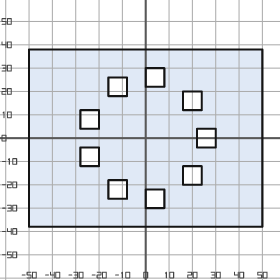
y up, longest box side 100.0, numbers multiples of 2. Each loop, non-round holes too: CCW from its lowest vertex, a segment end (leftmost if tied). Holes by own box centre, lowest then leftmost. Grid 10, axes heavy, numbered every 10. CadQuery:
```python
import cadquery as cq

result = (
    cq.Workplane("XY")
    .moveTo(-50.0, -38.0)
    .lineTo(50.0, -38.0)
    .lineTo(50.0, 38.0)
    .lineTo(-50.0, 38.0)
    .close()
    .moveTo(0.0, -30.0)
    .lineTo(8.0, -30.0)
    .lineTo(8.0, -22.0)
    .lineTo(0.0, -22.0)
    .close()
    .moveTo(-16.0, -26.0)
    .lineTo(-8.0, -26.0)
    .lineTo(-8.0, -18.0)
    .lineTo(-16.0, -18.0)
    .close()
    .moveTo(16.0, -20.0)
    .lineTo(24.0, -20.0)
    .lineTo(24.0, -12.0)
    .lineTo(16.0, -12.0)
    .close()
    .moveTo(-28.0, -12.0)
    .lineTo(-20.0, -12.0)
    .lineTo(-20.0, -4.0)
    .lineTo(-28.0, -4.0)
    .close()
    .moveTo(22.0, -4.0)
    .lineTo(30.0, -4.0)
    .lineTo(30.0, 4.0)
    .lineTo(22.0, 4.0)
    .close()
    .moveTo(-28.0, 4.0)
    .lineTo(-20.0, 4.0)
    .lineTo(-20.0, 12.0)
    .lineTo(-28.0, 12.0)
    .close()
    .moveTo(16.0, 12.0)
    .lineTo(24.0, 12.0)
    .lineTo(24.0, 20.0)
    .lineTo(16.0, 20.0)
    .close()
    .moveTo(-16.0, 18.0)
    .lineTo(-8.0, 18.0)
    .lineTo(-8.0, 26.0)
    .lineTo(-16.0, 26.0)
    .close()
    .moveTo(0.0, 22.0)
    .lineTo(8.0, 22.0)
    .lineTo(8.0, 30.0)
    .lineTo(0.0, 30.0)
    .close()
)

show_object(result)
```